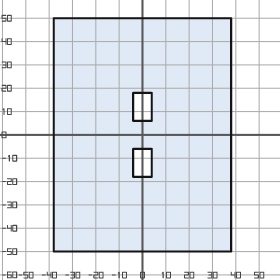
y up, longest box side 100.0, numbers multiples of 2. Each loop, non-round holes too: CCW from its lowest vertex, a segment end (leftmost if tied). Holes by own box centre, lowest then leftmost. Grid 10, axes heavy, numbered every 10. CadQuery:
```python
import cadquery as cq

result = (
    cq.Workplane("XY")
    .moveTo(-38.0, -50.0)
    .lineTo(38.0, -50.0)
    .lineTo(38.0, 50.0)
    .lineTo(-38.0, 50.0)
    .close()
    .moveTo(-4.0, -18.0)
    .lineTo(4.0, -18.0)
    .lineTo(4.0, -6.0)
    .lineTo(-4.0, -6.0)
    .close()
    .moveTo(-4.0, 6.0)
    .lineTo(4.0, 6.0)
    .lineTo(4.0, 18.0)
    .lineTo(-4.0, 18.0)
    .close()
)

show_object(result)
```